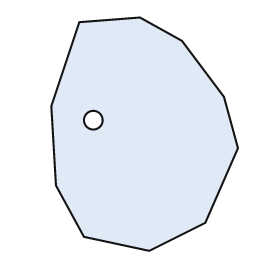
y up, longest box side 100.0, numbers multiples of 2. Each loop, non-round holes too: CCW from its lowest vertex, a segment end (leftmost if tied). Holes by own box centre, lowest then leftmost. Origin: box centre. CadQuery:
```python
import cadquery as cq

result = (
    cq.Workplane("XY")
    .moveTo(2.0, -50.0)
    .lineTo(26.0, -38.0)
    .lineTo(40.0, -6.0)
    .lineTo(34.0, 16.0)
    .lineTo(16.0, 40.0)
    .lineTo(-2.0, 50.0)
    .lineTo(-28.0, 48.0)
    .lineTo(-40.0, 12.0)
    .lineTo(-38.0, -22.0)
    .lineTo(-26.0, -44.0)
    .close()
    .moveTo(-22.0, 6.0)
    .circle(4.0)
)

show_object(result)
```